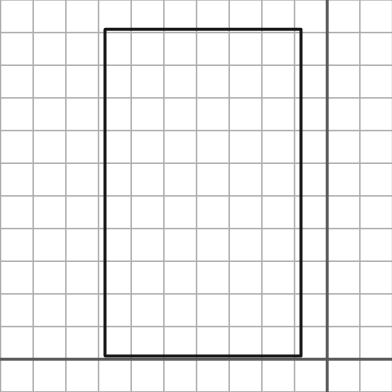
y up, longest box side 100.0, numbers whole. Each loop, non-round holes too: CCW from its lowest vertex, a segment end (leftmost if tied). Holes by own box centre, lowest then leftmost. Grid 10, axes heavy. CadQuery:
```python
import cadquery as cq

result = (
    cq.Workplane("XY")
    .moveTo(-68.0, 1.0)
    .lineTo(-8.0, 1.0)
    .lineTo(-8.0, 101.0)
    .lineTo(-68.0, 101.0)
    .close()
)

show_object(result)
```